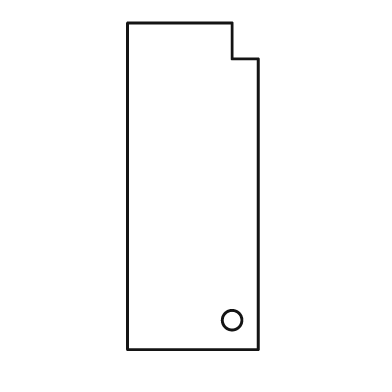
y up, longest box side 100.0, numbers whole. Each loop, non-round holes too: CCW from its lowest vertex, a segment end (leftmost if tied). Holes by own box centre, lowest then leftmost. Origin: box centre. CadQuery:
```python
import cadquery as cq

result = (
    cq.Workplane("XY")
    .moveTo(-20.0, -50.0)
    .lineTo(20.0, -50.0)
    .lineTo(20.0, 39.0)
    .lineTo(12.0, 39.0)
    .lineTo(12.0, 50.0)
    .lineTo(-20.0, 50.0)
    .close()
    .moveTo(12.0, -41.0)
    .circle(3.0)
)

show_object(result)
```